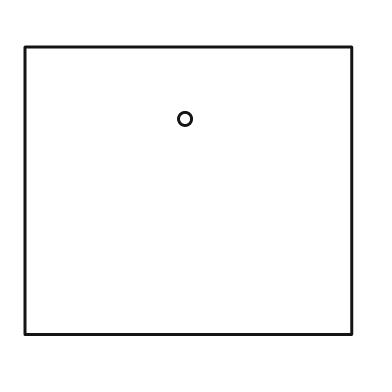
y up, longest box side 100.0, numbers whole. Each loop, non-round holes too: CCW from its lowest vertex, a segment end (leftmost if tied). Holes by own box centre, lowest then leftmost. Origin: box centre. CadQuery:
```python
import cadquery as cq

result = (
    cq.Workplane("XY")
    .moveTo(-50.0, -44.0)
    .lineTo(50.0, -44.0)
    .lineTo(50.0, 44.0)
    .lineTo(-50.0, 44.0)
    .close()
    .moveTo(-1.0, 22.0)
    .circle(2.0)
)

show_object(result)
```